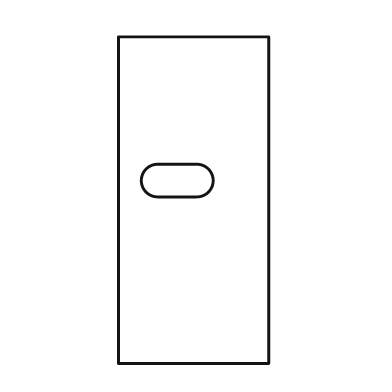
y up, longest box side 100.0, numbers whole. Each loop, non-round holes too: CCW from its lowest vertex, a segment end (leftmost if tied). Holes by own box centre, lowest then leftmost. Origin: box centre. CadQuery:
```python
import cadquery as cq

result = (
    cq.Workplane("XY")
    .moveTo(-23.0, -50.0)
    .lineTo(23.0, -50.0)
    .lineTo(23.0, 50.0)
    .lineTo(-23.0, 50.0)
    .close()
    .moveTo(-11.0, 1.0)
    .lineTo(1.0, 1.0)
    .threePointArc((6.0, 6.0), (1.0, 11.0))
    .lineTo(-11.0, 11.0)
    .threePointArc((-16.0, 6.0), (-11.0, 1.0))
    .close()
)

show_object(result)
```